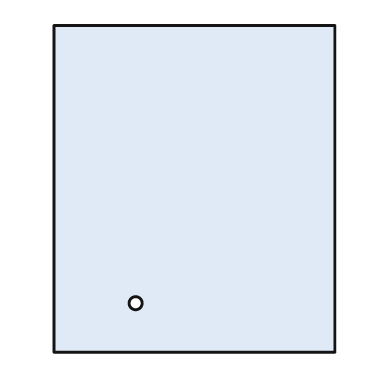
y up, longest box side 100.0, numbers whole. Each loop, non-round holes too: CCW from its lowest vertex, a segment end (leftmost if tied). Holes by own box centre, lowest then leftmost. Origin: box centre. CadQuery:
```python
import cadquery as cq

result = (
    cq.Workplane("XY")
    .moveTo(-43.0, -50.0)
    .lineTo(43.0, -50.0)
    .lineTo(43.0, 50.0)
    .lineTo(-43.0, 50.0)
    .close()
    .moveTo(-18.0, -35.0)
    .circle(2.0)
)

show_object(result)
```